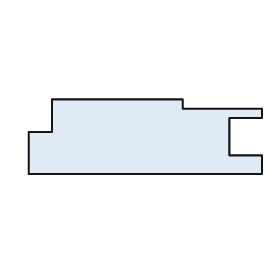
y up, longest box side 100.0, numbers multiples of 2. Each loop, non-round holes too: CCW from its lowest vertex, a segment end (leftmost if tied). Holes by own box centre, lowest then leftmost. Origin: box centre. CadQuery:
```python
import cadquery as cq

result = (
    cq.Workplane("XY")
    .moveTo(-50.0, -16.0)
    .lineTo(50.0, -16.0)
    .lineTo(50.0, -8.0)
    .lineTo(36.0, -8.0)
    .lineTo(36.0, 8.0)
    .lineTo(50.0, 8.0)
    .lineTo(50.0, 12.0)
    .lineTo(16.0, 12.0)
    .lineTo(16.0, 16.0)
    .lineTo(-40.0, 16.0)
    .lineTo(-40.0, 2.0)
    .lineTo(-50.0, 2.0)
    .close()
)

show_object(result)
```